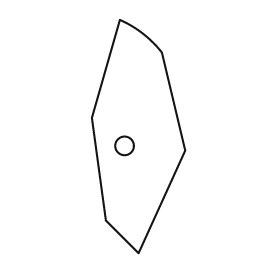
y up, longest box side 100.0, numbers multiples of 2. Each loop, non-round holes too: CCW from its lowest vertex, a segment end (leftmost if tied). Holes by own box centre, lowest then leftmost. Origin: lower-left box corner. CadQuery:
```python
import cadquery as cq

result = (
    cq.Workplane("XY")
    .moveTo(20.0, 0.0)
    .lineTo(40.0, 44.0)
    .lineTo(30.0, 86.0)
    .threePointArc((22.0, 94.0), (12.0, 100.0))
    .lineTo(0.0, 58.0)
    .lineTo(6.0, 14.0)
    .close()
    .moveTo(14.0, 46.0)
    .circle(4.0)
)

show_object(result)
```